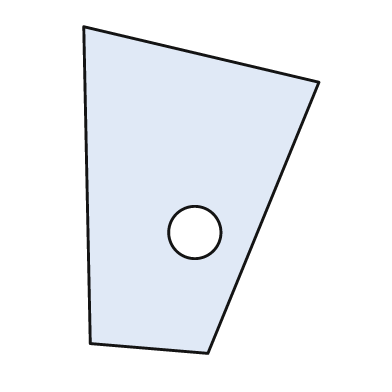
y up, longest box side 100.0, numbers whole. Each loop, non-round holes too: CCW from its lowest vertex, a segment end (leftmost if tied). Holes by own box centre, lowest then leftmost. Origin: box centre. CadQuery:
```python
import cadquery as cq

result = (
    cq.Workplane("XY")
    .moveTo(2.0, -50.0)
    .lineTo(36.0, 33.0)
    .lineTo(-36.0, 50.0)
    .lineTo(-34.0, -47.0)
    .close()
    .moveTo(-2.0, -13.0)
    .circle(8.0)
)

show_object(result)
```